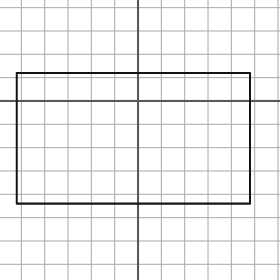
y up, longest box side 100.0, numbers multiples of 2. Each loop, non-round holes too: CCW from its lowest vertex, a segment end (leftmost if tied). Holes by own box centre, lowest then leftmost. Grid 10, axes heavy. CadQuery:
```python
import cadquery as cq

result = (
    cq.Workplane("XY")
    .moveTo(-52.0, -44.0)
    .lineTo(48.0, -44.0)
    .lineTo(48.0, 12.0)
    .lineTo(-52.0, 12.0)
    .close()
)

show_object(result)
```